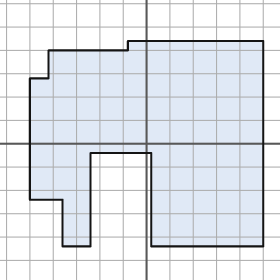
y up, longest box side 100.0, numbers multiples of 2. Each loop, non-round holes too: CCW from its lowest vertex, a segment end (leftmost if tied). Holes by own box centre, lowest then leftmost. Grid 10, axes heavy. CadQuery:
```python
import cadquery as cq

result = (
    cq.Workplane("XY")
    .moveTo(-36.0, -44.0)
    .lineTo(-24.0, -44.0)
    .lineTo(-24.0, -4.0)
    .lineTo(2.0, -4.0)
    .lineTo(2.0, -44.0)
    .lineTo(50.0, -44.0)
    .lineTo(50.0, 44.0)
    .lineTo(-8.0, 44.0)
    .lineTo(-8.0, 40.0)
    .lineTo(-42.0, 40.0)
    .lineTo(-42.0, 28.0)
    .lineTo(-50.0, 28.0)
    .lineTo(-50.0, -24.0)
    .lineTo(-36.0, -24.0)
    .close()
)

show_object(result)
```